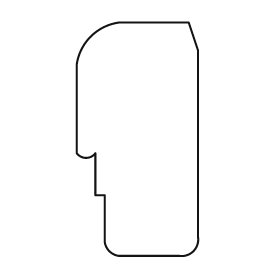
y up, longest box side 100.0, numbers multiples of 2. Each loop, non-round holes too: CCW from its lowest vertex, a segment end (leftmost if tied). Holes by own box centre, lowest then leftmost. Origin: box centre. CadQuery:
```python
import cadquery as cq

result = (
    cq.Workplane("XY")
    .moveTo(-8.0, -50.0)
    .lineTo(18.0, -50.0)
    .threePointArc((24.0, -48.0), (26.0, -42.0))
    .lineTo(26.0, 38.0)
    .lineTo(22.0, 50.0)
    .lineTo(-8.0, 50.0)
    .threePointArc((-20.0, 44.0), (-26.0, 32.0))
    .lineTo(-26.0, -6.0)
    .threePointArc((-22.0, -8.0), (-18.0, -6.0))
    .lineTo(-18.0, -24.0)
    .lineTo(-14.0, -24.0)
    .lineTo(-14.0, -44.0)
    .threePointArc((-12.0, -48.0), (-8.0, -50.0))
    .close()
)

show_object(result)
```